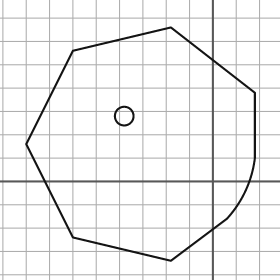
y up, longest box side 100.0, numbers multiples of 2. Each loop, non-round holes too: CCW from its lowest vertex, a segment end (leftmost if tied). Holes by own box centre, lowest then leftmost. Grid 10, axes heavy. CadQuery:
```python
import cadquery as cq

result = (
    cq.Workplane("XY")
    .moveTo(-18.0, -34.0)
    .lineTo(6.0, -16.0)
    .threePointArc((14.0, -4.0), (18.0, 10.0))
    .lineTo(18.0, 38.0)
    .lineTo(-18.0, 66.0)
    .lineTo(-60.0, 56.0)
    .lineTo(-80.0, 16.0)
    .lineTo(-60.0, -24.0)
    .close()
    .moveTo(-38.0, 28.0)
    .circle(4.0)
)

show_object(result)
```